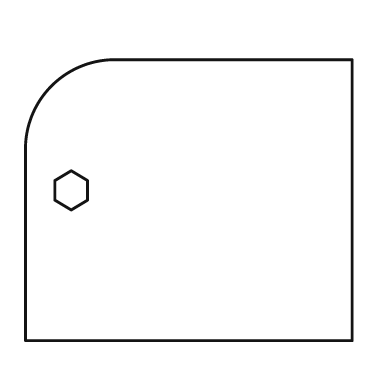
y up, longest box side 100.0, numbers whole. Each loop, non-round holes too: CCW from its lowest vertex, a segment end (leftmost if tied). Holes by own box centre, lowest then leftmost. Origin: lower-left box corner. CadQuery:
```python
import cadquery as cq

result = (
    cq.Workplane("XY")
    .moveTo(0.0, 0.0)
    .lineTo(100.0, 0.0)
    .lineTo(100.0, 86.0)
    .lineTo(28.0, 86.0)
    .threePointArc((8.0, 78.0), (0.0, 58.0))
    .close()
    .moveTo(14.0, 40.0)
    .lineTo(19.0, 43.0)
    .lineTo(19.0, 49.0)
    .lineTo(14.0, 52.0)
    .lineTo(9.0, 49.0)
    .lineTo(9.0, 43.0)
    .close()
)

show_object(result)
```